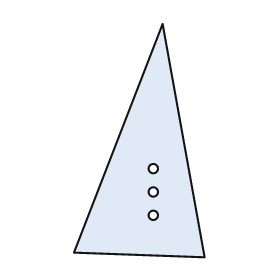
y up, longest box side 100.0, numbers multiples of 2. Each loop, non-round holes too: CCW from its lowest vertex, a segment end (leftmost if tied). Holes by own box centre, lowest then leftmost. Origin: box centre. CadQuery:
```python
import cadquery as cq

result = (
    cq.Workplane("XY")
    .moveTo(28.0, -50.0)
    .lineTo(10.0, 50.0)
    .lineTo(-28.0, -48.0)
    .close()
    .moveTo(6.0, -32.0)
    .circle(2.0)
    .moveTo(6.0, -22.0)
    .circle(2.0)
    .moveTo(6.0, -12.0)
    .circle(2.0)
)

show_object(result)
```